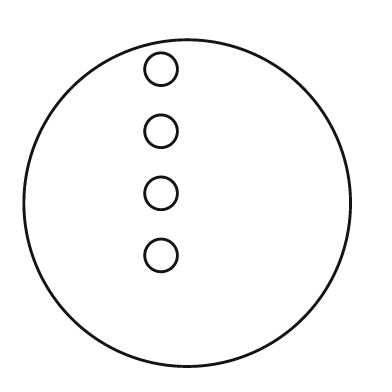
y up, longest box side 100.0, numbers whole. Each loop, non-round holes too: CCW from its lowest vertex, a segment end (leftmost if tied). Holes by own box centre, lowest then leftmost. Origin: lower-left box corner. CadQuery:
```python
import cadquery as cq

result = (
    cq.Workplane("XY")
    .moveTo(50.0, 50.0)
    .circle(50.0)
    .moveTo(42.0, 34.0)
    .circle(5.0)
    .moveTo(42.0, 53.0)
    .circle(5.0)
    .moveTo(42.0, 72.0)
    .circle(5.0)
    .moveTo(42.0, 91.0)
    .circle(5.0)
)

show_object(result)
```